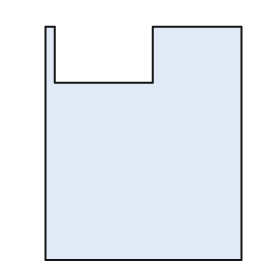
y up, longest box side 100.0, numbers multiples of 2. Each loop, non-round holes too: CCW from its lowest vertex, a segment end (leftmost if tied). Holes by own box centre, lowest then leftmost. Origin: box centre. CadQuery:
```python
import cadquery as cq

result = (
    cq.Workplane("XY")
    .moveTo(-42.0, -50.0)
    .lineTo(42.0, -50.0)
    .lineTo(42.0, 50.0)
    .lineTo(4.0, 50.0)
    .lineTo(4.0, 26.0)
    .lineTo(-38.0, 26.0)
    .lineTo(-38.0, 50.0)
    .lineTo(-42.0, 50.0)
    .close()
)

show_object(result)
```